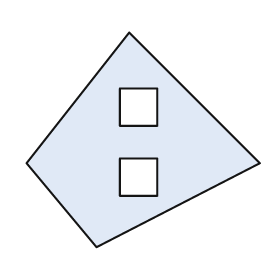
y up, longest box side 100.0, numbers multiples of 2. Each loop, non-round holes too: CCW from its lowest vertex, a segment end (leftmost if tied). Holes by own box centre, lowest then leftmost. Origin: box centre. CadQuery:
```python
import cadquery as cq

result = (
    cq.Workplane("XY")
    .moveTo(-20.0, -46.0)
    .lineTo(50.0, -10.0)
    .lineTo(-6.0, 46.0)
    .lineTo(-50.0, -10.0)
    .close()
    .moveTo(-10.0, -24.0)
    .lineTo(6.0, -24.0)
    .lineTo(6.0, -8.0)
    .lineTo(-10.0, -8.0)
    .close()
    .moveTo(-10.0, 6.0)
    .lineTo(6.0, 6.0)
    .lineTo(6.0, 22.0)
    .lineTo(-10.0, 22.0)
    .close()
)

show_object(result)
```